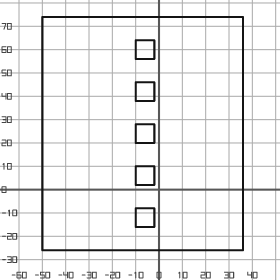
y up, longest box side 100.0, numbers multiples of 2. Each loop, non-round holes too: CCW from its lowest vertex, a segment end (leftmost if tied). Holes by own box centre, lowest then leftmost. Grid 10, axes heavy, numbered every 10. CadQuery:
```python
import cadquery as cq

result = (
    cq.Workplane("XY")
    .moveTo(-50.0, -26.0)
    .lineTo(36.0, -26.0)
    .lineTo(36.0, 74.0)
    .lineTo(-50.0, 74.0)
    .close()
    .moveTo(-10.0, -16.0)
    .lineTo(-2.0, -16.0)
    .lineTo(-2.0, -8.0)
    .lineTo(-10.0, -8.0)
    .close()
    .moveTo(-10.0, 2.0)
    .lineTo(-2.0, 2.0)
    .lineTo(-2.0, 10.0)
    .lineTo(-10.0, 10.0)
    .close()
    .moveTo(-10.0, 20.0)
    .lineTo(-2.0, 20.0)
    .lineTo(-2.0, 28.0)
    .lineTo(-10.0, 28.0)
    .close()
    .moveTo(-10.0, 38.0)
    .lineTo(-2.0, 38.0)
    .lineTo(-2.0, 46.0)
    .lineTo(-10.0, 46.0)
    .close()
    .moveTo(-10.0, 56.0)
    .lineTo(-2.0, 56.0)
    .lineTo(-2.0, 64.0)
    .lineTo(-10.0, 64.0)
    .close()
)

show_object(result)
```